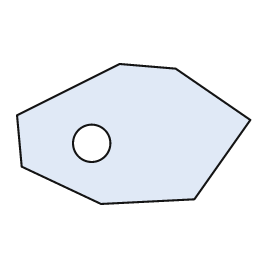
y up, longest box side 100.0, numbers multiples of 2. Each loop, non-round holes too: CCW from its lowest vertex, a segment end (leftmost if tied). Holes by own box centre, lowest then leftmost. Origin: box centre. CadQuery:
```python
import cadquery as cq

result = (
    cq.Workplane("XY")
    .moveTo(-14.0, -30.0)
    .lineTo(26.0, -28.0)
    .lineTo(50.0, 6.0)
    .lineTo(18.0, 28.0)
    .lineTo(-6.0, 30.0)
    .lineTo(-50.0, 8.0)
    .lineTo(-48.0, -14.0)
    .close()
    .moveTo(-18.0, -4.0)
    .circle(8.0)
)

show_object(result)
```